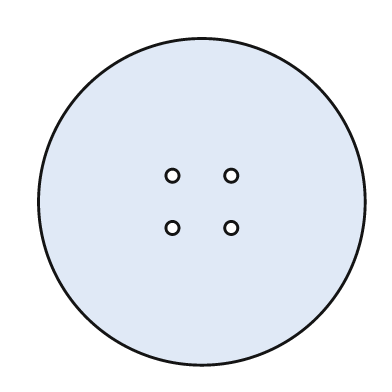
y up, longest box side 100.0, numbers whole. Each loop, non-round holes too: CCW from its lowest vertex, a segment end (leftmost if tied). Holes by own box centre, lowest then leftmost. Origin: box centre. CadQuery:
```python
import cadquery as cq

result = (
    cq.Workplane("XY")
    .moveTo(0.0, 0.0)
    .circle(50.0)
    .moveTo(-9.0, -8.0)
    .circle(2.0)
    .moveTo(9.0, -8.0)
    .circle(2.0)
    .moveTo(-9.0, 8.0)
    .circle(2.0)
    .moveTo(9.0, 8.0)
    .circle(2.0)
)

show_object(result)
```